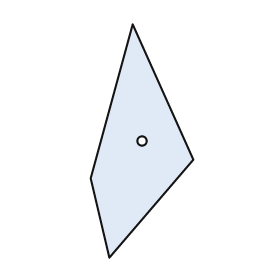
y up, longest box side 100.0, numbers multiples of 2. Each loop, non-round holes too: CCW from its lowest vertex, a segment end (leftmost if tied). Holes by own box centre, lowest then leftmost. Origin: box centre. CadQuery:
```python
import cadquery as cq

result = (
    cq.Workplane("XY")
    .moveTo(-14.0, -50.0)
    .lineTo(22.0, -8.0)
    .lineTo(-4.0, 50.0)
    .lineTo(-22.0, -16.0)
    .close()
    .moveTo(0.0, 0.0)
    .circle(2.0)
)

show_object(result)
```